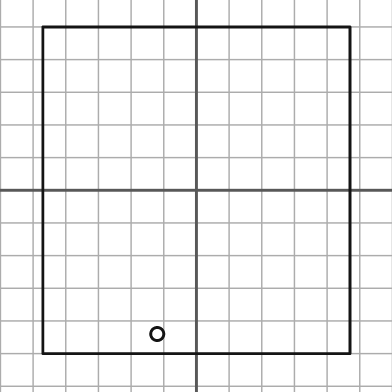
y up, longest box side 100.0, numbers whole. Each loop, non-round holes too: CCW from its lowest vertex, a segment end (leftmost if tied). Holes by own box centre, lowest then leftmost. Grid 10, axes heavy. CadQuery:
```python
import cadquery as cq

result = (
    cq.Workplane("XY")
    .moveTo(-47.0, -50.0)
    .lineTo(47.0, -50.0)
    .lineTo(47.0, 50.0)
    .lineTo(-47.0, 50.0)
    .close()
    .moveTo(-12.0, -44.0)
    .circle(2.0)
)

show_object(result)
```